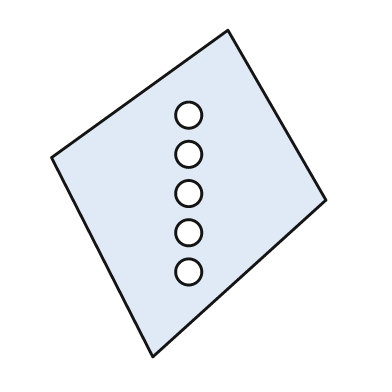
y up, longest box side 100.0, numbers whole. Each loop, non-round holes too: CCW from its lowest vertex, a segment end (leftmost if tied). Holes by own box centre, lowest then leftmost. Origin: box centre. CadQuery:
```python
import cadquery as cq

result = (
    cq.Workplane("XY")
    .moveTo(-11.0, -50.0)
    .lineTo(42.0, -2.0)
    .lineTo(12.0, 50.0)
    .lineTo(-42.0, 11.0)
    .close()
    .moveTo(0.0, -24.0)
    .circle(4.0)
    .moveTo(0.0, -12.0)
    .circle(4.0)
    .moveTo(0.0, 0.0)
    .circle(4.0)
    .moveTo(0.0, 12.0)
    .circle(4.0)
    .moveTo(0.0, 24.0)
    .circle(4.0)
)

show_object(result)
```